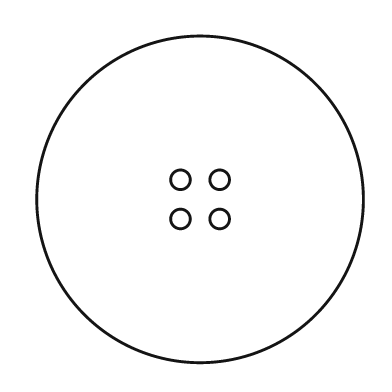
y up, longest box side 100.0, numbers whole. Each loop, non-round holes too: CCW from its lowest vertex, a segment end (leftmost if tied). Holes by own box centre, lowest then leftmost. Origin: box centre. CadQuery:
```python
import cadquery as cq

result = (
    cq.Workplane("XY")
    .moveTo(0.0, 0.0)
    .circle(50.0)
    .moveTo(-6.0, -6.0)
    .circle(3.0)
    .moveTo(6.0, -6.0)
    .circle(3.0)
    .moveTo(-6.0, 6.0)
    .circle(3.0)
    .moveTo(6.0, 6.0)
    .circle(3.0)
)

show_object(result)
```